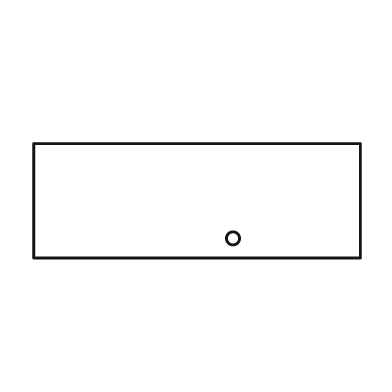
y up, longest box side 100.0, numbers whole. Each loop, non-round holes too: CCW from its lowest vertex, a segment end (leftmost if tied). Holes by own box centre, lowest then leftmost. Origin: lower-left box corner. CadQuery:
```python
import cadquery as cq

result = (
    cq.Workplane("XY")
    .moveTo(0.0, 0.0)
    .lineTo(100.0, 0.0)
    .lineTo(100.0, 35.0)
    .lineTo(0.0, 35.0)
    .close()
    .moveTo(61.0, 6.0)
    .circle(2.0)
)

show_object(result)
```